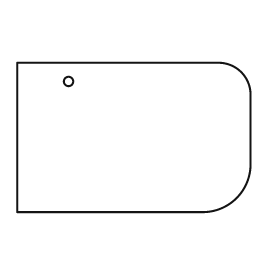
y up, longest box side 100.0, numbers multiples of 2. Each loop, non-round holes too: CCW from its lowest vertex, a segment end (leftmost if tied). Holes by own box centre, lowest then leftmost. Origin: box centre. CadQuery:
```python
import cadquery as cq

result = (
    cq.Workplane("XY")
    .moveTo(-50.0, -32.0)
    .lineTo(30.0, -32.0)
    .threePointArc((44.0, -26.0), (50.0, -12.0))
    .lineTo(50.0, 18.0)
    .threePointArc((46.0, 28.0), (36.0, 32.0))
    .lineTo(-50.0, 32.0)
    .close()
    .moveTo(-28.0, 24.0)
    .circle(2.0)
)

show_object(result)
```